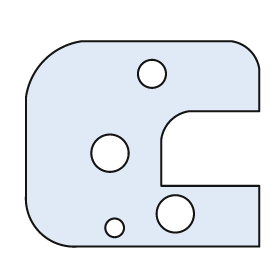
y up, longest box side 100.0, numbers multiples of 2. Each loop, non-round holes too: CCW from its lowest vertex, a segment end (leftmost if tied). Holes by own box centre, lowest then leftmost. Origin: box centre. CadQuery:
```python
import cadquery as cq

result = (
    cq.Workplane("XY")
    .moveTo(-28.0, -44.0)
    .lineTo(50.0, -44.0)
    .lineTo(50.0, -18.0)
    .lineTo(8.0, -18.0)
    .lineTo(8.0, 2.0)
    .threePointArc((12.0, 10.0), (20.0, 14.0))
    .lineTo(50.0, 14.0)
    .lineTo(50.0, 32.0)
    .threePointArc((46.0, 40.0), (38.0, 44.0))
    .lineTo(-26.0, 44.0)
    .threePointArc((-42.0, 36.0), (-50.0, 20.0))
    .lineTo(-50.0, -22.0)
    .threePointArc((-44.0, -38.0), (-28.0, -44.0))
    .close()
    .moveTo(-12.0, -36.0)
    .circle(4.0)
    .moveTo(14.0, -30.0)
    .circle(8.0)
    .moveTo(-14.0, -4.0)
    .circle(8.0)
    .moveTo(4.0, 30.0)
    .circle(6.0)
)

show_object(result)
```